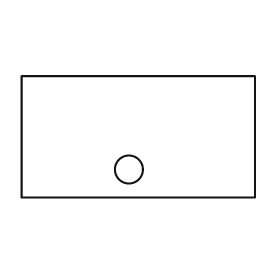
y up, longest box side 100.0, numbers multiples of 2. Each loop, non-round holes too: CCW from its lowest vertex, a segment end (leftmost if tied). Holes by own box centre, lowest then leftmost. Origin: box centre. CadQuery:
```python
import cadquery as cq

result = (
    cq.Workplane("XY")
    .moveTo(-50.0, -26.0)
    .lineTo(50.0, -26.0)
    .lineTo(50.0, 26.0)
    .lineTo(-50.0, 26.0)
    .close()
    .moveTo(-4.0, -14.0)
    .circle(6.0)
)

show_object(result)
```